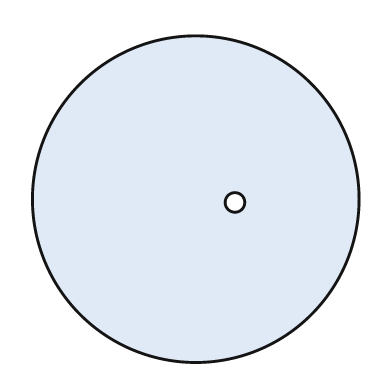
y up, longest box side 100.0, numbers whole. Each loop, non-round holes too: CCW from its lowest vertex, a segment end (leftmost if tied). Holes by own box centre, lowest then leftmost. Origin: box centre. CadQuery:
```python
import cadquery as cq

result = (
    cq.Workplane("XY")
    .moveTo(0.0, 0.0)
    .circle(50.0)
    .moveTo(12.0, -1.0)
    .circle(3.0)
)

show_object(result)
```